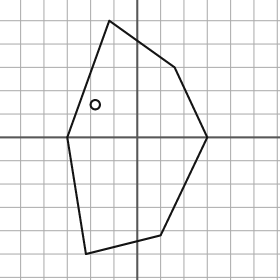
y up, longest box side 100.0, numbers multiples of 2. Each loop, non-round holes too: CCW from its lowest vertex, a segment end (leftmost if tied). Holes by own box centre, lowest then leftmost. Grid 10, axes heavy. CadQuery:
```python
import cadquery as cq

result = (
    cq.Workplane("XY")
    .moveTo(-22.0, -50.0)
    .lineTo(10.0, -42.0)
    .lineTo(30.0, 0.0)
    .lineTo(16.0, 30.0)
    .lineTo(-12.0, 50.0)
    .lineTo(-30.0, 0.0)
    .close()
    .moveTo(-18.0, 14.0)
    .circle(2.0)
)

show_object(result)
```